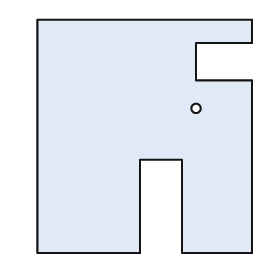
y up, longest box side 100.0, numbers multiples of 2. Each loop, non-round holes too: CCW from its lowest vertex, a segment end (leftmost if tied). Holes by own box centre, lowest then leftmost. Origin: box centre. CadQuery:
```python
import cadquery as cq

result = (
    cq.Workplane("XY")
    .moveTo(-46.0, -50.0)
    .lineTo(-2.0, -50.0)
    .lineTo(-2.0, -10.0)
    .lineTo(16.0, -10.0)
    .lineTo(16.0, -50.0)
    .lineTo(46.0, -50.0)
    .lineTo(46.0, 24.0)
    .lineTo(22.0, 24.0)
    .lineTo(22.0, 40.0)
    .lineTo(46.0, 40.0)
    .lineTo(46.0, 50.0)
    .lineTo(-46.0, 50.0)
    .close()
    .moveTo(22.0, 12.0)
    .circle(2.0)
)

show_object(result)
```